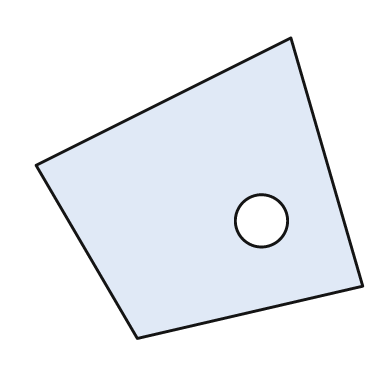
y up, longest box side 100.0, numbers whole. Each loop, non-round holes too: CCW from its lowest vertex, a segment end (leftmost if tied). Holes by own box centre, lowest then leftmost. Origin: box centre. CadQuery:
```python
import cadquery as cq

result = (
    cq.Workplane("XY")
    .moveTo(-19.0, -46.0)
    .lineTo(50.0, -30.0)
    .lineTo(28.0, 46.0)
    .lineTo(-50.0, 7.0)
    .close()
    .moveTo(19.0, -10.0)
    .circle(8.0)
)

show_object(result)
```